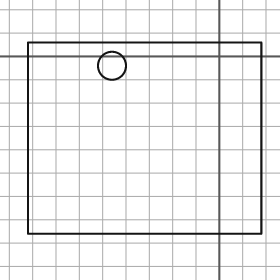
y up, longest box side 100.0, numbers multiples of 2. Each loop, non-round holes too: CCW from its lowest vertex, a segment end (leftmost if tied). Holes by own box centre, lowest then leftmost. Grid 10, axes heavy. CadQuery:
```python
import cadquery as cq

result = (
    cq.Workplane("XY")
    .moveTo(-82.0, -76.0)
    .lineTo(18.0, -76.0)
    .lineTo(18.0, 6.0)
    .lineTo(-82.0, 6.0)
    .close()
    .moveTo(-46.0, -4.0)
    .circle(6.0)
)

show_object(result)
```